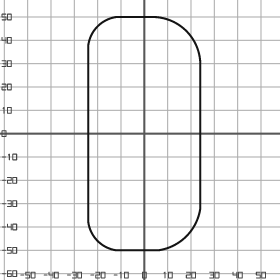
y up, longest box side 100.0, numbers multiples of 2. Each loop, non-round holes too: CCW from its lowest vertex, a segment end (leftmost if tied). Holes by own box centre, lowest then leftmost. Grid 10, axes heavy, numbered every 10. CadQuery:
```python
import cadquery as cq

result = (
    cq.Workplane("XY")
    .moveTo(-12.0, -50.0)
    .lineTo(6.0, -50.0)
    .threePointArc((18.0, -44.0), (24.0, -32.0))
    .lineTo(24.0, 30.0)
    .threePointArc((18.0, 44.0), (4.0, 50.0))
    .lineTo(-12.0, 50.0)
    .threePointArc((-20.0, 46.0), (-24.0, 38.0))
    .lineTo(-24.0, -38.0)
    .threePointArc((-20.0, -46.0), (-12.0, -50.0))
    .close()
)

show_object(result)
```